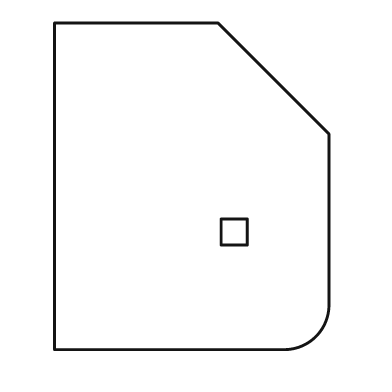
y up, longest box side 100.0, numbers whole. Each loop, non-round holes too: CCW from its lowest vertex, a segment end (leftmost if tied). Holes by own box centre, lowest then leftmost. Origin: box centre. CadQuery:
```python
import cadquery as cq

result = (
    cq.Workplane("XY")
    .moveTo(-42.0, -50.0)
    .lineTo(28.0, -50.0)
    .threePointArc((38.0, -46.0), (42.0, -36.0))
    .lineTo(42.0, 16.0)
    .lineTo(8.0, 50.0)
    .lineTo(-42.0, 50.0)
    .close()
    .moveTo(9.0, -18.0)
    .lineTo(17.0, -18.0)
    .lineTo(17.0, -10.0)
    .lineTo(9.0, -10.0)
    .close()
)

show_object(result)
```